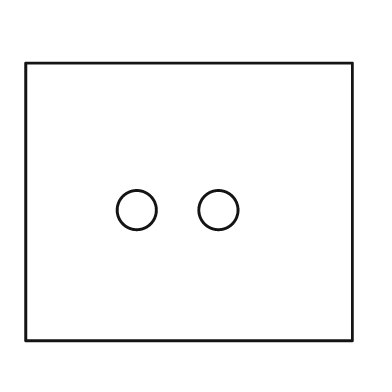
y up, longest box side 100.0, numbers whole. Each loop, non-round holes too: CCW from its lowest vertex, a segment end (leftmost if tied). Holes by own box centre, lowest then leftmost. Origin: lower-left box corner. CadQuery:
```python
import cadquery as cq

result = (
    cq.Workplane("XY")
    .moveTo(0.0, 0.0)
    .lineTo(100.0, 0.0)
    .lineTo(100.0, 85.0)
    .lineTo(0.0, 85.0)
    .close()
    .moveTo(34.0, 40.0)
    .circle(6.0)
    .moveTo(59.0, 40.0)
    .circle(6.0)
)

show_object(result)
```